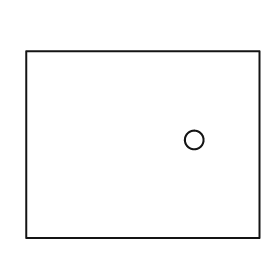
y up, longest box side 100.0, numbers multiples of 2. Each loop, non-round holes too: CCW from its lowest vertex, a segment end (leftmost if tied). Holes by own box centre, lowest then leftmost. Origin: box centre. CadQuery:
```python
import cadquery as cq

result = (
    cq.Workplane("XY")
    .moveTo(-50.0, -40.0)
    .lineTo(50.0, -40.0)
    .lineTo(50.0, 40.0)
    .lineTo(-50.0, 40.0)
    .close()
    .moveTo(22.0, 2.0)
    .circle(4.0)
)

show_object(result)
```